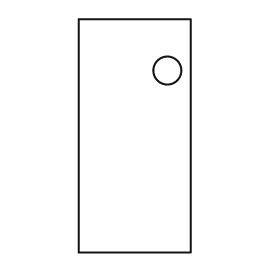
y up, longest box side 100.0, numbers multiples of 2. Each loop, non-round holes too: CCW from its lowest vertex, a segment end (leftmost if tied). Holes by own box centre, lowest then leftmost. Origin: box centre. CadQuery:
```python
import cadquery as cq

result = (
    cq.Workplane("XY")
    .moveTo(-24.0, -50.0)
    .lineTo(24.0, -50.0)
    .lineTo(24.0, 50.0)
    .lineTo(-24.0, 50.0)
    .close()
    .moveTo(14.0, 28.0)
    .circle(6.0)
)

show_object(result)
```